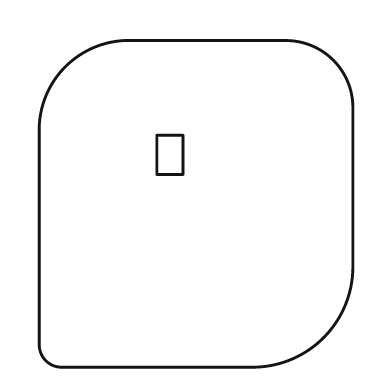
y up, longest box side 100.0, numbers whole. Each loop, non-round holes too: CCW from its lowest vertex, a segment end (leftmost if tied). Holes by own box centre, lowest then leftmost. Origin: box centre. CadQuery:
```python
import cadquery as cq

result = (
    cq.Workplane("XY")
    .moveTo(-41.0, -50.0)
    .lineTo(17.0, -50.0)
    .threePointArc((39.0, -41.0), (48.0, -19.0))
    .lineTo(48.0, 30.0)
    .threePointArc((42.0, 44.0), (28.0, 50.0))
    .lineTo(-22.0, 50.0)
    .threePointArc((-40.0, 42.0), (-48.0, 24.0))
    .lineTo(-48.0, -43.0)
    .threePointArc((-46.0, -48.0), (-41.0, -50.0))
    .close()
    .moveTo(-12.0, 9.0)
    .lineTo(-4.0, 9.0)
    .lineTo(-4.0, 21.0)
    .lineTo(-12.0, 21.0)
    .close()
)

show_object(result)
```